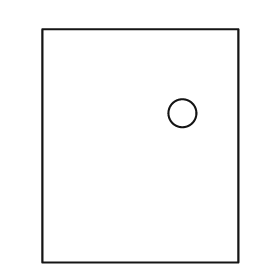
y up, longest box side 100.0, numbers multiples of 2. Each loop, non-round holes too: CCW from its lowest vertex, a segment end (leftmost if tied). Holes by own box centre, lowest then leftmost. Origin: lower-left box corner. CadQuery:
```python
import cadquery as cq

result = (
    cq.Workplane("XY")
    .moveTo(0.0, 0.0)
    .lineTo(84.0, 0.0)
    .lineTo(84.0, 100.0)
    .lineTo(0.0, 100.0)
    .close()
    .moveTo(60.0, 64.0)
    .circle(6.0)
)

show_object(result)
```